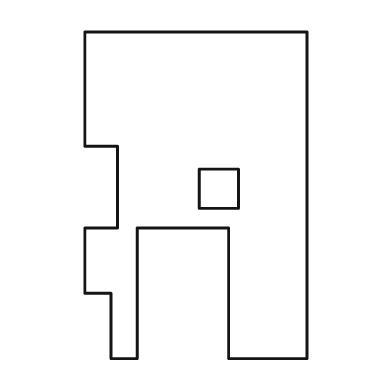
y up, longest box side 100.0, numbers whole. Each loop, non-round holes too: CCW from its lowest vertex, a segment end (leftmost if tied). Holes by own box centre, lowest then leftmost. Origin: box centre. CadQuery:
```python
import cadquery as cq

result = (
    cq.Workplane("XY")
    .moveTo(-26.0, -50.0)
    .lineTo(-18.0, -50.0)
    .lineTo(-18.0, -10.0)
    .lineTo(10.0, -10.0)
    .lineTo(10.0, -50.0)
    .lineTo(34.0, -50.0)
    .lineTo(34.0, 50.0)
    .lineTo(-34.0, 50.0)
    .lineTo(-34.0, 15.0)
    .lineTo(-24.0, 15.0)
    .lineTo(-24.0, -10.0)
    .lineTo(-34.0, -10.0)
    .lineTo(-34.0, -30.0)
    .lineTo(-26.0, -30.0)
    .close()
    .moveTo(1.0, -4.0)
    .lineTo(13.0, -4.0)
    .lineTo(13.0, 8.0)
    .lineTo(1.0, 8.0)
    .close()
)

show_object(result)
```